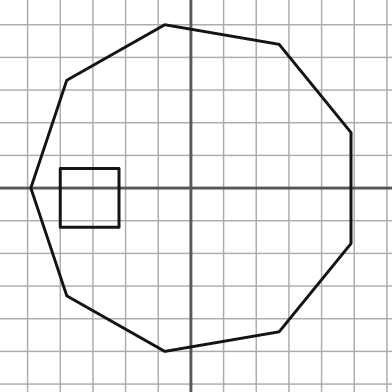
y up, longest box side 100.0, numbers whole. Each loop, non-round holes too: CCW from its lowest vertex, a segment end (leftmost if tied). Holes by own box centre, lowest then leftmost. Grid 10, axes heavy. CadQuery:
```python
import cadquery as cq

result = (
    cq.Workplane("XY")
    .moveTo(-8.0, -50.0)
    .lineTo(27.0, -44.0)
    .lineTo(49.0, -17.0)
    .lineTo(49.0, 17.0)
    .lineTo(27.0, 44.0)
    .lineTo(-8.0, 50.0)
    .lineTo(-38.0, 33.0)
    .lineTo(-49.0, 0.0)
    .lineTo(-38.0, -33.0)
    .close()
    .moveTo(-40.0, -12.0)
    .lineTo(-22.0, -12.0)
    .lineTo(-22.0, 6.0)
    .lineTo(-40.0, 6.0)
    .close()
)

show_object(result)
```